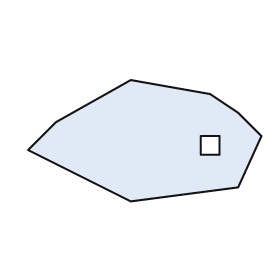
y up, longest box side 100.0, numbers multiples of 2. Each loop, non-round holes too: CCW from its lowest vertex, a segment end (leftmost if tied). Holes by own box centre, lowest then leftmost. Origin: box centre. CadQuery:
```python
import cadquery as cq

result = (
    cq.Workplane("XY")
    .moveTo(-6.0, -26.0)
    .lineTo(40.0, -20.0)
    .lineTo(50.0, 2.0)
    .lineTo(40.0, 12.0)
    .lineTo(28.0, 20.0)
    .lineTo(-6.0, 26.0)
    .lineTo(-38.0, 8.0)
    .lineTo(-50.0, -4.0)
    .close()
    .moveTo(24.0, -6.0)
    .lineTo(32.0, -6.0)
    .lineTo(32.0, 2.0)
    .lineTo(24.0, 2.0)
    .close()
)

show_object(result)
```